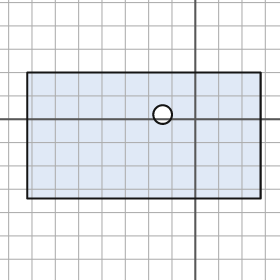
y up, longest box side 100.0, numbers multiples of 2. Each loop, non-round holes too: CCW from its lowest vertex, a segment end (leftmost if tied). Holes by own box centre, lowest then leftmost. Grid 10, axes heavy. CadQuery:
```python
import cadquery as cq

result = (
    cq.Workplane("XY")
    .moveTo(-72.0, -34.0)
    .lineTo(28.0, -34.0)
    .lineTo(28.0, 20.0)
    .lineTo(-72.0, 20.0)
    .close()
    .moveTo(-14.0, 2.0)
    .circle(4.0)
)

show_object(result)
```